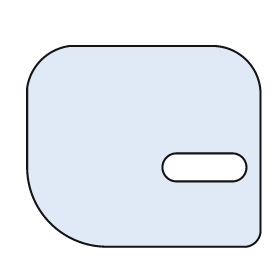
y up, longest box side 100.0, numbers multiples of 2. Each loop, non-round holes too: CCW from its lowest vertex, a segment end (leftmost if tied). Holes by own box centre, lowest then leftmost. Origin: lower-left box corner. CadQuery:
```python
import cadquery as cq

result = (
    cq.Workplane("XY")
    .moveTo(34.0, 0.0)
    .lineTo(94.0, 0.0)
    .threePointArc((98.0, 2.0), (100.0, 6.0))
    .lineTo(100.0, 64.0)
    .threePointArc((94.0, 80.0), (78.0, 86.0))
    .lineTo(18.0, 86.0)
    .threePointArc((6.0, 80.0), (0.0, 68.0))
    .lineTo(0.0, 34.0)
    .threePointArc((10.0, 10.0), (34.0, 0.0))
    .close()
    .moveTo(64.0, 28.0)
    .lineTo(88.0, 28.0)
    .threePointArc((94.0, 34.0), (88.0, 40.0))
    .lineTo(64.0, 40.0)
    .threePointArc((58.0, 34.0), (64.0, 28.0))
    .close()
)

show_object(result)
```